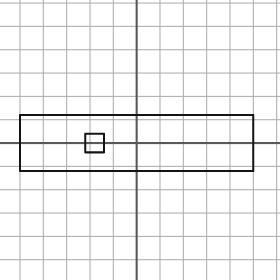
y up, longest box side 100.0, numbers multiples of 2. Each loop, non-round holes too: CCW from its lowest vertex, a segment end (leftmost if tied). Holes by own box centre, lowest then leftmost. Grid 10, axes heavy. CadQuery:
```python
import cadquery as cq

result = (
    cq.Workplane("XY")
    .moveTo(-50.0, -12.0)
    .lineTo(50.0, -12.0)
    .lineTo(50.0, 12.0)
    .lineTo(-50.0, 12.0)
    .close()
    .moveTo(-22.0, -4.0)
    .lineTo(-14.0, -4.0)
    .lineTo(-14.0, 4.0)
    .lineTo(-22.0, 4.0)
    .close()
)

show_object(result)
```